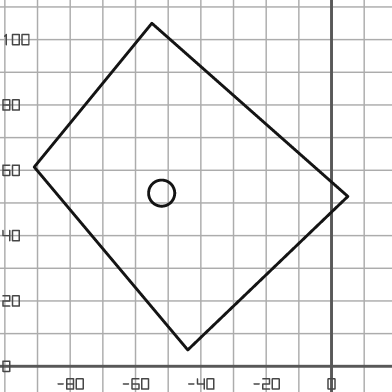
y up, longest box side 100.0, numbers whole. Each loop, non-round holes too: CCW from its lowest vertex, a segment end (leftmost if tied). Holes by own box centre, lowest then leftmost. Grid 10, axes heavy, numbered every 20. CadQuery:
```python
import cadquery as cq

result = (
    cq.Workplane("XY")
    .moveTo(-44.0, 5.0)
    .lineTo(5.0, 52.0)
    .lineTo(-55.0, 105.0)
    .lineTo(-91.0, 61.0)
    .close()
    .moveTo(-52.0, 53.0)
    .circle(4.0)
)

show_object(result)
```